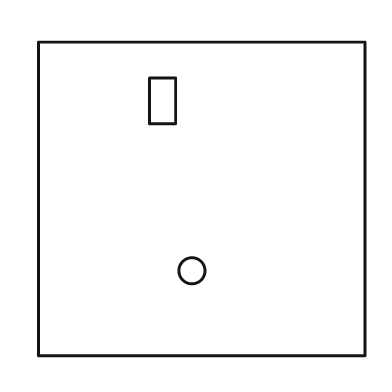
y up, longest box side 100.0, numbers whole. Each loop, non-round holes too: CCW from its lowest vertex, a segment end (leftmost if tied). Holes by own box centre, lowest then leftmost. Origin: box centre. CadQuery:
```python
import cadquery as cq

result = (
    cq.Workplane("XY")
    .moveTo(-50.0, -48.0)
    .lineTo(50.0, -48.0)
    .lineTo(50.0, 48.0)
    .lineTo(-50.0, 48.0)
    .close()
    .moveTo(-3.0, -22.0)
    .circle(4.0)
    .moveTo(-16.0, 23.0)
    .lineTo(-8.0, 23.0)
    .lineTo(-8.0, 37.0)
    .lineTo(-16.0, 37.0)
    .close()
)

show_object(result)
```